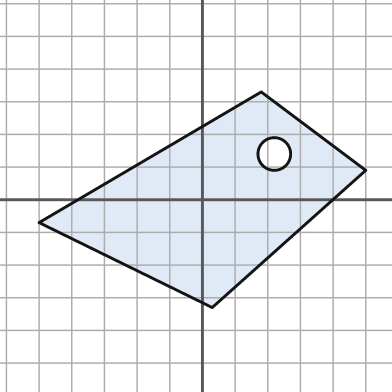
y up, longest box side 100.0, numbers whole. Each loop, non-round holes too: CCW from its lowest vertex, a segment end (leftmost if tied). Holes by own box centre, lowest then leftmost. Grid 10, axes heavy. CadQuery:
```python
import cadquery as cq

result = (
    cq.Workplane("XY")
    .moveTo(3.0, -33.0)
    .lineTo(50.0, 9.0)
    .lineTo(18.0, 33.0)
    .lineTo(-50.0, -7.0)
    .close()
    .moveTo(22.0, 14.0)
    .circle(5.0)
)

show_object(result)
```